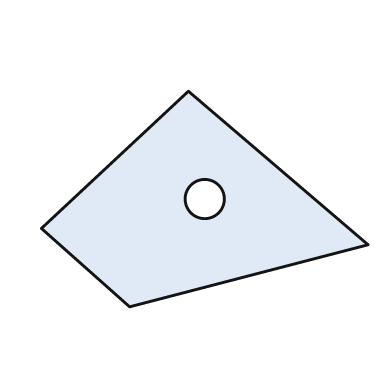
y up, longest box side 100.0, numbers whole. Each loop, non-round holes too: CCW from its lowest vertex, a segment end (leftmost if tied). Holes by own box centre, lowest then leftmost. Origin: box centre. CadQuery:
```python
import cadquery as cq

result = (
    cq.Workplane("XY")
    .moveTo(-23.0, -33.0)
    .lineTo(50.0, -14.0)
    .lineTo(-5.0, 33.0)
    .lineTo(-50.0, -9.0)
    .close()
    .moveTo(0.0, 0.0)
    .circle(6.0)
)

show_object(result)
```